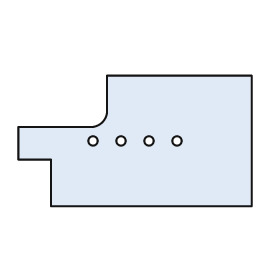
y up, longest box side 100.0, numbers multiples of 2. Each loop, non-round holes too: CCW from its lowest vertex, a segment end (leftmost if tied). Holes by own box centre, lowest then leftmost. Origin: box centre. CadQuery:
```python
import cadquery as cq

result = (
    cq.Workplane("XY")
    .moveTo(-36.0, -28.0)
    .lineTo(50.0, -28.0)
    .lineTo(50.0, 28.0)
    .lineTo(-12.0, 28.0)
    .lineTo(-12.0, 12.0)
    .threePointArc((-14.0, 8.0), (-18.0, 6.0))
    .lineTo(-50.0, 6.0)
    .lineTo(-50.0, -8.0)
    .lineTo(-36.0, -8.0)
    .close()
    .moveTo(-18.0, 0.0)
    .circle(2.0)
    .moveTo(-6.0, 0.0)
    .circle(2.0)
    .moveTo(6.0, 0.0)
    .circle(2.0)
    .moveTo(18.0, 0.0)
    .circle(2.0)
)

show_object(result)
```